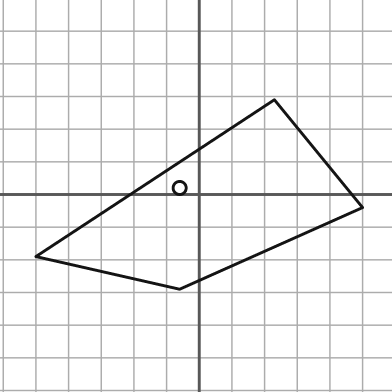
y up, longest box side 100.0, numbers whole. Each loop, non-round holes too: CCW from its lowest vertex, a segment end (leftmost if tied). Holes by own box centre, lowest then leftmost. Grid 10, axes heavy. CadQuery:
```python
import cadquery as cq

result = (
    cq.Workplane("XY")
    .moveTo(-6.0, -29.0)
    .lineTo(50.0, -4.0)
    .lineTo(23.0, 29.0)
    .lineTo(-50.0, -19.0)
    .close()
    .moveTo(-6.0, 2.0)
    .circle(2.0)
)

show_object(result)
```